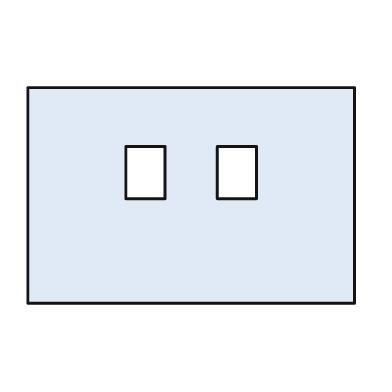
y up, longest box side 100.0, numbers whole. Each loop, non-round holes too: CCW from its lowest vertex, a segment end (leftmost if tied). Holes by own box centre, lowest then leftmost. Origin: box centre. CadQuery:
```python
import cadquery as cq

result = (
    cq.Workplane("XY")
    .moveTo(-50.0, -33.0)
    .lineTo(50.0, -33.0)
    .lineTo(50.0, 33.0)
    .lineTo(-50.0, 33.0)
    .close()
    .moveTo(-20.0, -1.0)
    .lineTo(-8.0, -1.0)
    .lineTo(-8.0, 15.0)
    .lineTo(-20.0, 15.0)
    .close()
    .moveTo(8.0, -1.0)
    .lineTo(20.0, -1.0)
    .lineTo(20.0, 15.0)
    .lineTo(8.0, 15.0)
    .close()
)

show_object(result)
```